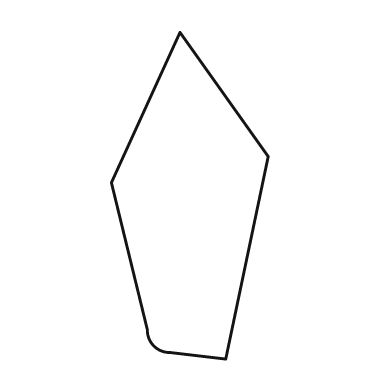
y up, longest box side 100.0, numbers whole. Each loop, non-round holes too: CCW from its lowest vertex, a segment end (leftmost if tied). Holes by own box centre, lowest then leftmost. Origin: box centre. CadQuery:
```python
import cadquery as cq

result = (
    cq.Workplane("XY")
    .moveTo(11.0, -50.0)
    .lineTo(24.0, 12.0)
    .lineTo(-3.0, 50.0)
    .lineTo(-24.0, 4.0)
    .lineTo(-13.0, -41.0)
    .threePointArc((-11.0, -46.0), (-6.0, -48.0))
    .close()
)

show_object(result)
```